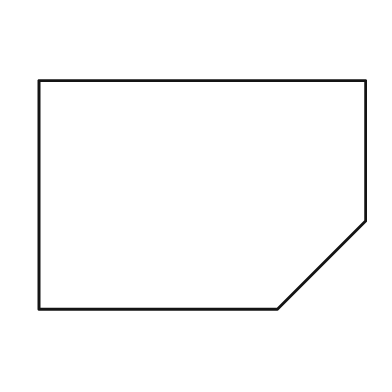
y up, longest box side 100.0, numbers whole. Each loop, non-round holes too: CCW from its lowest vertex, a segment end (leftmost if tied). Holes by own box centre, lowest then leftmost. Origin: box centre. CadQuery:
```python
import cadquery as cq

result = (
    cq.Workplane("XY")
    .moveTo(-50.0, -35.0)
    .lineTo(23.0, -35.0)
    .lineTo(50.0, -8.0)
    .lineTo(50.0, 35.0)
    .lineTo(-50.0, 35.0)
    .close()
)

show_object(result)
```